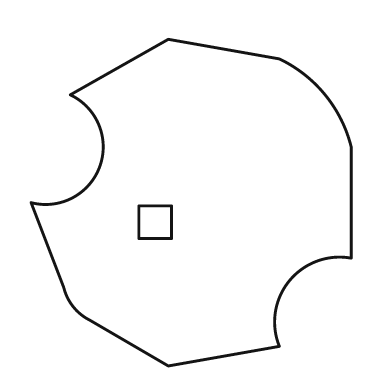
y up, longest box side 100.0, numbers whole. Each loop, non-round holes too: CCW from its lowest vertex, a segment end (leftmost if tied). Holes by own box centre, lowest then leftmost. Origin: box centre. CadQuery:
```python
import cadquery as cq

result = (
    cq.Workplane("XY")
    .moveTo(-7.0, -50.0)
    .lineTo(27.0, -44.0)
    .threePointArc((30.0, -24.0), (49.0, -17.0))
    .lineTo(49.0, 17.0)
    .threePointArc((41.0, 33.0), (27.0, 44.0))
    .lineTo(-7.0, 50.0)
    .lineTo(-37.0, 33.0)
    .threePointArc((-28.0, 11.0), (-49.0, 0.0))
    .lineTo(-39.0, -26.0)
    .threePointArc((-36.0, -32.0), (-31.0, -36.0))
    .close()
    .moveTo(-16.0, -11.0)
    .lineTo(-6.0, -11.0)
    .lineTo(-6.0, -1.0)
    .lineTo(-16.0, -1.0)
    .close()
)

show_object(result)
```